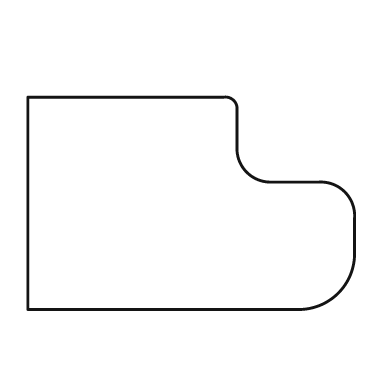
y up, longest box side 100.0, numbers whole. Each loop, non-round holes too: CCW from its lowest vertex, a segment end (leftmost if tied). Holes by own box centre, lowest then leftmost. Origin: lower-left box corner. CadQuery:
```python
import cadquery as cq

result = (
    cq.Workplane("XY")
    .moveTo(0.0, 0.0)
    .lineTo(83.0, 0.0)
    .threePointArc((95.0, 5.0), (100.0, 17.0))
    .lineTo(100.0, 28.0)
    .threePointArc((97.0, 36.0), (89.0, 39.0))
    .lineTo(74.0, 39.0)
    .threePointArc((67.0, 42.0), (64.0, 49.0))
    .lineTo(64.0, 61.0)
    .threePointArc((63.0, 64.0), (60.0, 65.0))
    .lineTo(0.0, 65.0)
    .close()
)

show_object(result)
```